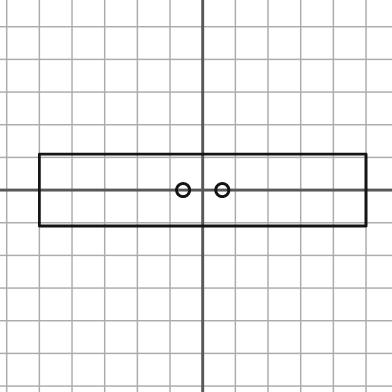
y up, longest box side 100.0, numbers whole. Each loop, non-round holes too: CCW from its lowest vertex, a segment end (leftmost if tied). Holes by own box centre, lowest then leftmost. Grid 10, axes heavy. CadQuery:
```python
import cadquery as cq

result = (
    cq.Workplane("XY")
    .moveTo(-50.0, -11.0)
    .lineTo(50.0, -11.0)
    .lineTo(50.0, 11.0)
    .lineTo(-50.0, 11.0)
    .close()
    .moveTo(-6.0, 0.0)
    .circle(2.0)
    .moveTo(6.0, 0.0)
    .circle(2.0)
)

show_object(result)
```